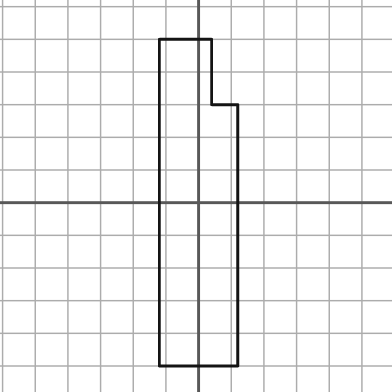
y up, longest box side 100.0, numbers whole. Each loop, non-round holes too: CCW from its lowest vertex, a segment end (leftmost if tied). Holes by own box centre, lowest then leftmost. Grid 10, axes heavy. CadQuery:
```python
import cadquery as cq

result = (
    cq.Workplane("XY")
    .moveTo(-12.0, -50.0)
    .lineTo(12.0, -50.0)
    .lineTo(12.0, 30.0)
    .lineTo(4.0, 30.0)
    .lineTo(4.0, 50.0)
    .lineTo(-12.0, 50.0)
    .close()
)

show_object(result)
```